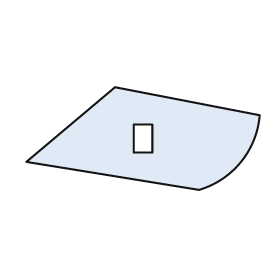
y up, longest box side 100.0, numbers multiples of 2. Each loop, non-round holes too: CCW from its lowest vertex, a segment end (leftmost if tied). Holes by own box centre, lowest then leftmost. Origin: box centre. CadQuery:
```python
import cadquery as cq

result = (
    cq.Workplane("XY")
    .moveTo(24.0, -22.0)
    .threePointArc((42.0, -10.0), (50.0, 10.0))
    .lineTo(-12.0, 22.0)
    .lineTo(-50.0, -10.0)
    .close()
    .moveTo(-4.0, -6.0)
    .lineTo(4.0, -6.0)
    .lineTo(4.0, 6.0)
    .lineTo(-4.0, 6.0)
    .close()
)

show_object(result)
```